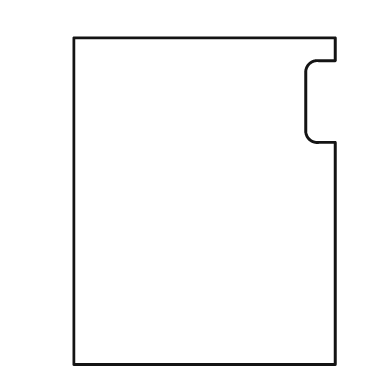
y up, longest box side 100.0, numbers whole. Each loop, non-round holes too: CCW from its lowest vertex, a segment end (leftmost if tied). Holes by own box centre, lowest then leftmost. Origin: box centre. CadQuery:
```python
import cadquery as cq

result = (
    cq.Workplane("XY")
    .moveTo(-40.0, -50.0)
    .lineTo(40.0, -50.0)
    .lineTo(40.0, 18.0)
    .lineTo(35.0, 18.0)
    .threePointArc((32.0, 19.0), (31.0, 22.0))
    .lineTo(31.0, 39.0)
    .threePointArc((32.0, 42.0), (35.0, 43.0))
    .lineTo(40.0, 43.0)
    .lineTo(40.0, 50.0)
    .lineTo(-40.0, 50.0)
    .close()
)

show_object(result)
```